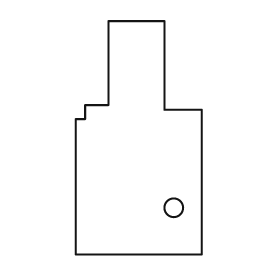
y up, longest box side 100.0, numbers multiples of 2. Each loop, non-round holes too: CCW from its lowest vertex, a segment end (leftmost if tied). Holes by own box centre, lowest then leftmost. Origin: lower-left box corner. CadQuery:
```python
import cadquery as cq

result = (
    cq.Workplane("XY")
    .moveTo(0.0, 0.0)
    .lineTo(54.0, 0.0)
    .lineTo(54.0, 62.0)
    .lineTo(38.0, 62.0)
    .lineTo(38.0, 100.0)
    .lineTo(14.0, 100.0)
    .lineTo(14.0, 64.0)
    .lineTo(4.0, 64.0)
    .lineTo(4.0, 58.0)
    .lineTo(0.0, 58.0)
    .close()
    .moveTo(42.0, 20.0)
    .circle(4.0)
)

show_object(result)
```